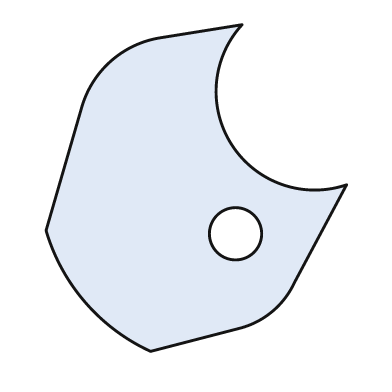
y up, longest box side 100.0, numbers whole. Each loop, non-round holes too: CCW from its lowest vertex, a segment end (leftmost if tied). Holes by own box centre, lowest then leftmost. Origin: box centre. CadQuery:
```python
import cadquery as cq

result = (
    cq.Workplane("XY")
    .moveTo(-14.0, -50.0)
    .lineTo(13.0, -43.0)
    .threePointArc((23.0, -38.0), (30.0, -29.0))
    .lineTo(46.0, 1.0)
    .threePointArc((11.0, 13.0), (14.0, 50.0))
    .lineTo(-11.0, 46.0)
    .threePointArc((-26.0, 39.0), (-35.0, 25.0))
    .lineTo(-46.0, -13.0)
    .threePointArc((-34.0, -35.0), (-14.0, -50.0))
    .close()
    .moveTo(12.0, -14.0)
    .circle(8.0)
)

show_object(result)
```